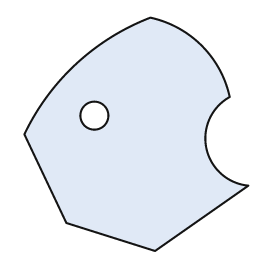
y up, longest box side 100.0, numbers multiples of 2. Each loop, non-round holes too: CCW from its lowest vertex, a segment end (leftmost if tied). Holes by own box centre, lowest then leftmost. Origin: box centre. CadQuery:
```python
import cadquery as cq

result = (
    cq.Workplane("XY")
    .moveTo(8.0, -50.0)
    .lineTo(48.0, -22.0)
    .threePointArc((30.0, -6.0), (40.0, 16.0))
    .threePointArc((28.0, 38.0), (6.0, 50.0))
    .threePointArc((-26.0, 30.0), (-48.0, 0.0))
    .lineTo(-30.0, -38.0)
    .close()
    .moveTo(-18.0, 8.0)
    .circle(6.0)
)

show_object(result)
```